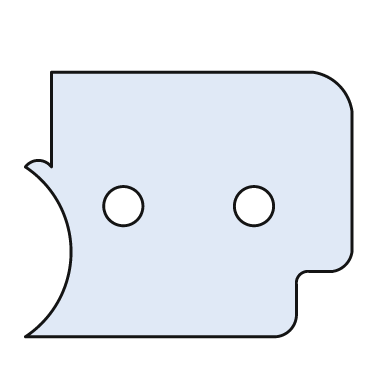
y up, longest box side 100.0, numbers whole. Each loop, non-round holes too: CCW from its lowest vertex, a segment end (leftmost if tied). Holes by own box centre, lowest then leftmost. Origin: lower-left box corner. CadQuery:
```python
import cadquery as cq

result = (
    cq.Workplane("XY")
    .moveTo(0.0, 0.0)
    .lineTo(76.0, 0.0)
    .threePointArc((81.0, 2.0), (83.0, 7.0))
    .lineTo(83.0, 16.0)
    .threePointArc((84.0, 19.0), (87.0, 20.0))
    .lineTo(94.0, 20.0)
    .threePointArc((98.0, 22.0), (100.0, 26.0))
    .lineTo(100.0, 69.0)
    .threePointArc((96.0, 77.0), (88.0, 81.0))
    .lineTo(8.0, 81.0)
    .lineTo(8.0, 52.0)
    .threePointArc((4.0, 54.0), (0.0, 52.0))
    .threePointArc((14.0, 26.0), (0.0, 0.0))
    .close()
    .moveTo(30.0, 40.0)
    .circle(6.0)
    .moveTo(70.0, 40.0)
    .circle(6.0)
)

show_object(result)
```